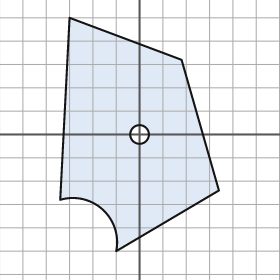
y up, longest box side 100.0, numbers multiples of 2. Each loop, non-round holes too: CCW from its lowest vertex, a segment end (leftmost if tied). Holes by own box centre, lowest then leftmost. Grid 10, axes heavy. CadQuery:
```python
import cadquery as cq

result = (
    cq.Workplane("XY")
    .moveTo(-10.0, -50.0)
    .lineTo(34.0, -24.0)
    .lineTo(18.0, 32.0)
    .lineTo(-30.0, 50.0)
    .lineTo(-34.0, -28.0)
    .threePointArc((-16.0, -32.0), (-10.0, -50.0))
    .close()
    .moveTo(0.0, 0.0)
    .circle(4.0)
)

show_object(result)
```